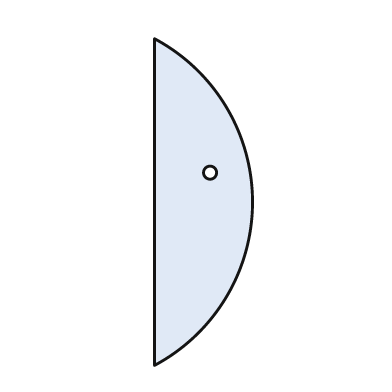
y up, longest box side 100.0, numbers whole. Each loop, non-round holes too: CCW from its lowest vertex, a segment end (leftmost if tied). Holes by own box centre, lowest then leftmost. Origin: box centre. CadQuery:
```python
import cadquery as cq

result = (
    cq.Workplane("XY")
    .moveTo(-15.0, -50.0)
    .threePointArc((15.0, 0.0), (-15.0, 50.0))
    .close()
    .moveTo(2.0, 9.0)
    .circle(2.0)
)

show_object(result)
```